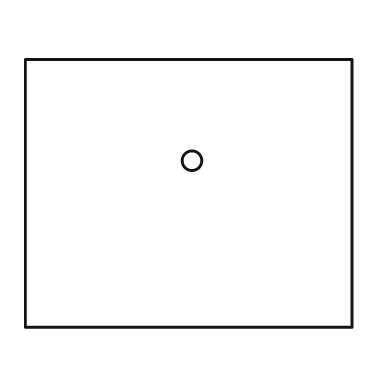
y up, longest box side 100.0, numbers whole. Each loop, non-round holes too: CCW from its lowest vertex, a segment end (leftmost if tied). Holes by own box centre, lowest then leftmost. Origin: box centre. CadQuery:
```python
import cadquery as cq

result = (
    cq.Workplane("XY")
    .moveTo(-50.0, -41.0)
    .lineTo(50.0, -41.0)
    .lineTo(50.0, 41.0)
    .lineTo(-50.0, 41.0)
    .close()
    .moveTo(1.0, 10.0)
    .circle(3.0)
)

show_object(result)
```